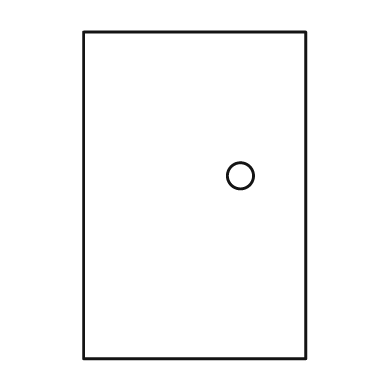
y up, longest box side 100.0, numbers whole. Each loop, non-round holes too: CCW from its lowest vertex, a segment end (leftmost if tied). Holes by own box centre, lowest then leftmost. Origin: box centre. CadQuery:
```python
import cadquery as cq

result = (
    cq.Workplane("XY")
    .moveTo(-34.0, -50.0)
    .lineTo(34.0, -50.0)
    .lineTo(34.0, 50.0)
    .lineTo(-34.0, 50.0)
    .close()
    .moveTo(14.0, 6.0)
    .circle(4.0)
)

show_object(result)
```